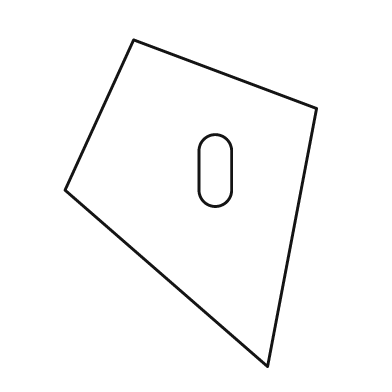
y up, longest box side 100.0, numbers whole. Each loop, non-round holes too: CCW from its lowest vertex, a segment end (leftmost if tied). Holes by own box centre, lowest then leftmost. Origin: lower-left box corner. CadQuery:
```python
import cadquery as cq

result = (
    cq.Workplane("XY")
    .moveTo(62.0, 0.0)
    .lineTo(77.0, 79.0)
    .lineTo(21.0, 100.0)
    .lineTo(0.0, 54.0)
    .close()
    .moveTo(41.0, 54.0)
    .threePointArc((46.0, 49.0), (51.0, 54.0))
    .lineTo(51.0, 66.0)
    .threePointArc((46.0, 71.0), (41.0, 66.0))
    .close()
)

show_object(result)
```